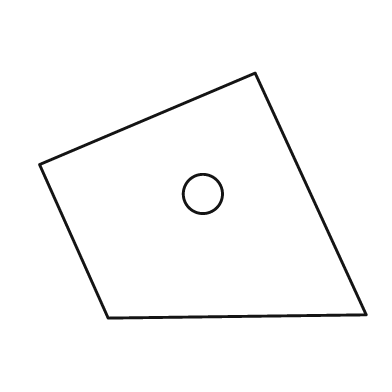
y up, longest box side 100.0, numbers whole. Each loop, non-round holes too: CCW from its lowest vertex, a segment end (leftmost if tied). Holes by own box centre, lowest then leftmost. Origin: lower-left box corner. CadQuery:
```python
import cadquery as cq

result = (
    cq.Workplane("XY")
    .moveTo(21.0, 0.0)
    .lineTo(100.0, 1.0)
    .lineTo(66.0, 75.0)
    .lineTo(0.0, 47.0)
    .close()
    .moveTo(50.0, 38.0)
    .circle(6.0)
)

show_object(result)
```